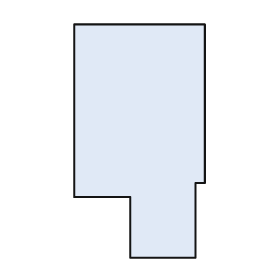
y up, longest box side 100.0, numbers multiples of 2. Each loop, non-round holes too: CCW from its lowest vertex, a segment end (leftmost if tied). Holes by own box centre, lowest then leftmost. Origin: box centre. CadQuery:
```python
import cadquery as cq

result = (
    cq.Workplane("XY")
    .moveTo(-4.0, -50.0)
    .lineTo(24.0, -50.0)
    .lineTo(24.0, -18.0)
    .lineTo(28.0, -18.0)
    .lineTo(28.0, 50.0)
    .lineTo(-28.0, 50.0)
    .lineTo(-28.0, -24.0)
    .lineTo(-4.0, -24.0)
    .close()
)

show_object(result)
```